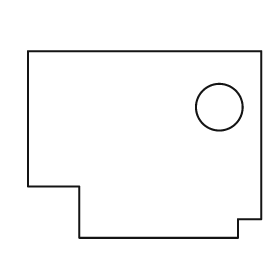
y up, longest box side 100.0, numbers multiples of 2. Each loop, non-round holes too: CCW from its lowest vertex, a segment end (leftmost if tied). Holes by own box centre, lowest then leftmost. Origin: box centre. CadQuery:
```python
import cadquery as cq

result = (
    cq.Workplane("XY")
    .moveTo(-28.0, -40.0)
    .lineTo(40.0, -40.0)
    .lineTo(40.0, -32.0)
    .lineTo(50.0, -32.0)
    .lineTo(50.0, 40.0)
    .lineTo(-50.0, 40.0)
    .lineTo(-50.0, -18.0)
    .lineTo(-28.0, -18.0)
    .close()
    .moveTo(32.0, 16.0)
    .circle(10.0)
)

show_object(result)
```